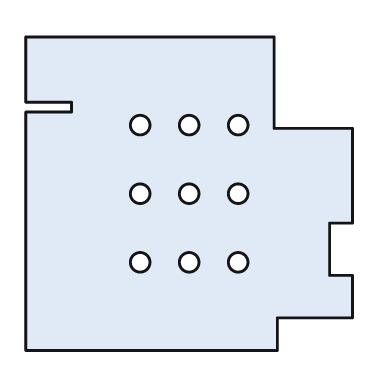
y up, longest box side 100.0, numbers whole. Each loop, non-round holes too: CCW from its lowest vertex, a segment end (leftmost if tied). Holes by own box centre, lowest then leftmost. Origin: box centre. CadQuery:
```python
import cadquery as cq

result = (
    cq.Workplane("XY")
    .moveTo(-50.0, -48.0)
    .lineTo(27.0, -48.0)
    .lineTo(27.0, -38.0)
    .lineTo(50.0, -38.0)
    .lineTo(50.0, -25.0)
    .lineTo(43.0, -25.0)
    .lineTo(43.0, -9.0)
    .lineTo(50.0, -9.0)
    .lineTo(50.0, 20.0)
    .lineTo(26.0, 20.0)
    .lineTo(26.0, 48.0)
    .lineTo(-50.0, 48.0)
    .lineTo(-50.0, 28.0)
    .lineTo(-36.0, 28.0)
    .lineTo(-36.0, 25.0)
    .lineTo(-50.0, 25.0)
    .close()
    .moveTo(-15.0, -21.0)
    .circle(3.0)
    .moveTo(0.0, -21.0)
    .circle(3.0)
    .moveTo(15.0, -21.0)
    .circle(3.0)
    .moveTo(-15.0, 0.0)
    .circle(3.0)
    .moveTo(0.0, 0.0)
    .circle(3.0)
    .moveTo(15.0, 0.0)
    .circle(3.0)
    .moveTo(-15.0, 21.0)
    .circle(3.0)
    .moveTo(0.0, 21.0)
    .circle(3.0)
    .moveTo(15.0, 21.0)
    .circle(3.0)
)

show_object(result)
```